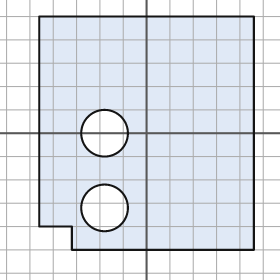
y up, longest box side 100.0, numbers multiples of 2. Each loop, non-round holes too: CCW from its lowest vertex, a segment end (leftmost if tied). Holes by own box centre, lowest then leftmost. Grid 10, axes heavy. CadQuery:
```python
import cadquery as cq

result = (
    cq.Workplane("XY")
    .moveTo(-32.0, -50.0)
    .lineTo(46.0, -50.0)
    .lineTo(46.0, 50.0)
    .lineTo(-46.0, 50.0)
    .lineTo(-46.0, -40.0)
    .lineTo(-32.0, -40.0)
    .close()
    .moveTo(-18.0, -32.0)
    .circle(10.0)
    .moveTo(-18.0, 0.0)
    .circle(10.0)
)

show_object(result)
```